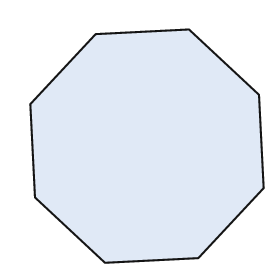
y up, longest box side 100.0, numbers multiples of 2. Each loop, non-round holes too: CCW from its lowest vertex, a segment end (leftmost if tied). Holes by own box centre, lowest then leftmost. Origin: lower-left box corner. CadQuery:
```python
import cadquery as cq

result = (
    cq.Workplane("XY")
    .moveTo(32.0, 0.0)
    .lineTo(72.0, 2.0)
    .lineTo(100.0, 32.0)
    .lineTo(98.0, 72.0)
    .lineTo(68.0, 100.0)
    .lineTo(28.0, 98.0)
    .lineTo(0.0, 68.0)
    .lineTo(2.0, 28.0)
    .close()
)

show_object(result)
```